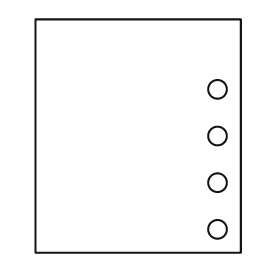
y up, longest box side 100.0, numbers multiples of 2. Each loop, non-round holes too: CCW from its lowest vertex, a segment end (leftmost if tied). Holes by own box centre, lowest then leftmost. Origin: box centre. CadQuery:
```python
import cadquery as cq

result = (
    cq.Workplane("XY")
    .moveTo(-44.0, -50.0)
    .lineTo(44.0, -50.0)
    .lineTo(44.0, 50.0)
    .lineTo(-44.0, 50.0)
    .close()
    .moveTo(34.0, -40.0)
    .circle(4.0)
    .moveTo(34.0, -20.0)
    .circle(4.0)
    .moveTo(34.0, 0.0)
    .circle(4.0)
    .moveTo(34.0, 20.0)
    .circle(4.0)
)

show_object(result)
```